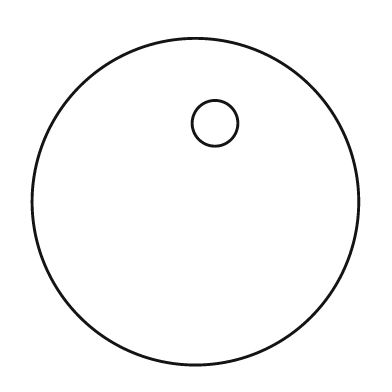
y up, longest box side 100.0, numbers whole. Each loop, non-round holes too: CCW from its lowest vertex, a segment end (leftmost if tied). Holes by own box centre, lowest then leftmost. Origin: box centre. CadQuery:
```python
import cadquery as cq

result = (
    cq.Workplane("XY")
    .moveTo(0.0, 0.0)
    .circle(50.0)
    .moveTo(6.0, 24.0)
    .circle(7.0)
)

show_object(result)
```